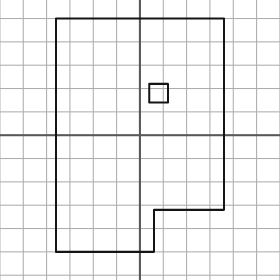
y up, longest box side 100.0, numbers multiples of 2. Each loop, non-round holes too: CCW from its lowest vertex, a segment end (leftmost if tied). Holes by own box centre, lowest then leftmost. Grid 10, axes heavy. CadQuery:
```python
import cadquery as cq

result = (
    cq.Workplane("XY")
    .moveTo(-36.0, -50.0)
    .lineTo(6.0, -50.0)
    .lineTo(6.0, -32.0)
    .lineTo(36.0, -32.0)
    .lineTo(36.0, 50.0)
    .lineTo(-36.0, 50.0)
    .close()
    .moveTo(4.0, 14.0)
    .lineTo(12.0, 14.0)
    .lineTo(12.0, 22.0)
    .lineTo(4.0, 22.0)
    .close()
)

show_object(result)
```